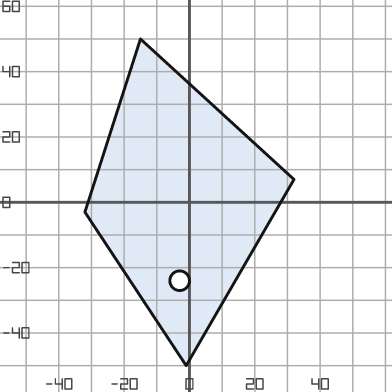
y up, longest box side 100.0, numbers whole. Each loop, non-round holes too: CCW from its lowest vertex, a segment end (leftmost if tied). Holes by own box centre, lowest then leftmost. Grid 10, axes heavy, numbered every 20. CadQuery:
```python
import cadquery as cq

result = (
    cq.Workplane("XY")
    .moveTo(-1.0, -50.0)
    .lineTo(32.0, 7.0)
    .lineTo(-15.0, 50.0)
    .lineTo(-32.0, -3.0)
    .close()
    .moveTo(-3.0, -24.0)
    .circle(3.0)
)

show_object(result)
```